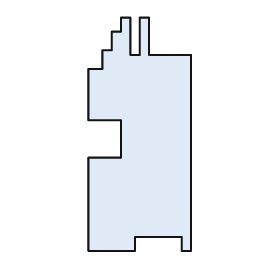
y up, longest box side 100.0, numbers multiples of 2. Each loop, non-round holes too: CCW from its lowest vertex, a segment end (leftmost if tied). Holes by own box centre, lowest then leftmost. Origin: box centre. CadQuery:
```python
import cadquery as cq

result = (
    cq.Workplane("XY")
    .moveTo(-22.0, -50.0)
    .lineTo(-2.0, -50.0)
    .lineTo(-2.0, -44.0)
    .lineTo(18.0, -44.0)
    .lineTo(18.0, -50.0)
    .lineTo(22.0, -50.0)
    .lineTo(22.0, 34.0)
    .lineTo(4.0, 34.0)
    .lineTo(4.0, 50.0)
    .lineTo(0.0, 50.0)
    .lineTo(0.0, 34.0)
    .lineTo(-4.0, 34.0)
    .lineTo(-4.0, 50.0)
    .lineTo(-8.0, 50.0)
    .lineTo(-8.0, 44.0)
    .lineTo(-12.0, 44.0)
    .lineTo(-12.0, 36.0)
    .lineTo(-16.0, 36.0)
    .lineTo(-16.0, 28.0)
    .lineTo(-22.0, 28.0)
    .lineTo(-22.0, 6.0)
    .lineTo(-8.0, 6.0)
    .lineTo(-8.0, -10.0)
    .lineTo(-22.0, -10.0)
    .close()
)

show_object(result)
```